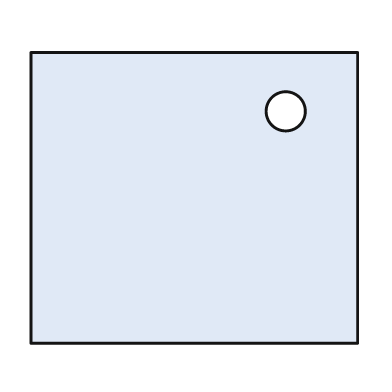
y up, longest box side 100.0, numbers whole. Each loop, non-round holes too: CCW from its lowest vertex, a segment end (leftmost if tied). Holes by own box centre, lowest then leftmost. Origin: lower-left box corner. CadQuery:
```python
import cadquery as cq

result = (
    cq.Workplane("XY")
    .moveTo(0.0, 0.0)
    .lineTo(100.0, 0.0)
    .lineTo(100.0, 89.0)
    .lineTo(0.0, 89.0)
    .close()
    .moveTo(78.0, 71.0)
    .circle(6.0)
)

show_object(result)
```